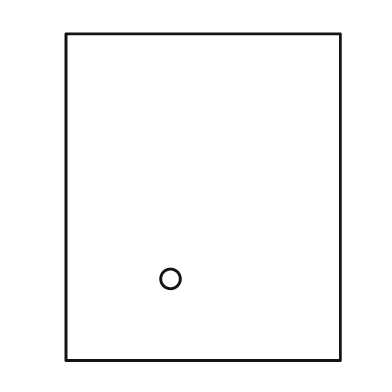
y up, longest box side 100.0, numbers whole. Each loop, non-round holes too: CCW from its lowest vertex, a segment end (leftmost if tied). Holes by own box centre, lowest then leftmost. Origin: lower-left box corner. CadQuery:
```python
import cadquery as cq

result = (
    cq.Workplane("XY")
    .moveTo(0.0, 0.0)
    .lineTo(84.0, 0.0)
    .lineTo(84.0, 100.0)
    .lineTo(0.0, 100.0)
    .close()
    .moveTo(32.0, 25.0)
    .circle(3.0)
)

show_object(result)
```